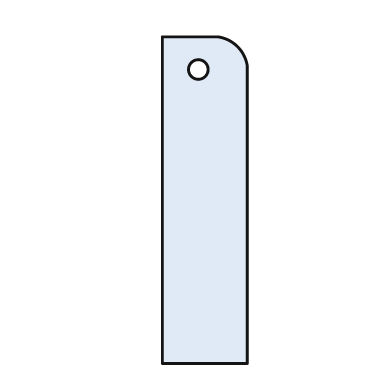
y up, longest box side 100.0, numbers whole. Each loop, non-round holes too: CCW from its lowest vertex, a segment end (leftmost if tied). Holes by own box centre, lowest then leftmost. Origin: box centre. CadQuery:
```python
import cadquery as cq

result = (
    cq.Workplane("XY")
    .moveTo(-13.0, -50.0)
    .lineTo(13.0, -50.0)
    .lineTo(13.0, 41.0)
    .threePointArc((10.0, 47.0), (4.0, 50.0))
    .lineTo(-13.0, 50.0)
    .close()
    .moveTo(-2.0, 40.0)
    .circle(3.0)
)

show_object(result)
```